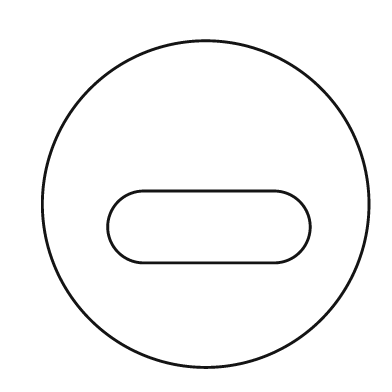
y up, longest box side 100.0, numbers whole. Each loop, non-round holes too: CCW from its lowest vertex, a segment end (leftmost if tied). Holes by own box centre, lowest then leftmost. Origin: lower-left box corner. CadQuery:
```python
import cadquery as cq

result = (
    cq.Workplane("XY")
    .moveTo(50.0, 50.0)
    .circle(50.0)
    .moveTo(31.0, 32.0)
    .lineTo(71.0, 32.0)
    .threePointArc((82.0, 43.0), (71.0, 54.0))
    .lineTo(31.0, 54.0)
    .threePointArc((20.0, 43.0), (31.0, 32.0))
    .close()
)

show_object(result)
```